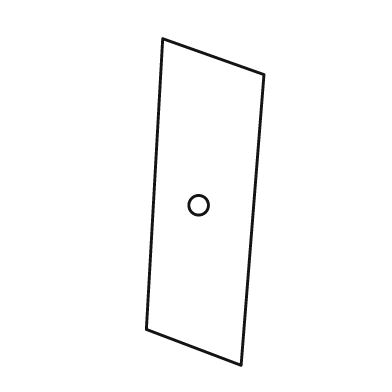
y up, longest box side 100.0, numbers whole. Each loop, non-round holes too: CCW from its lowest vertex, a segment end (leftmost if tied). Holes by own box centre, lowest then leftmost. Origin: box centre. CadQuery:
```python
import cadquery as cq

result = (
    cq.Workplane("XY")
    .moveTo(11.0, -50.0)
    .lineTo(18.0, 39.0)
    .lineTo(-13.0, 50.0)
    .lineTo(-18.0, -39.0)
    .close()
    .moveTo(-2.0, -1.0)
    .circle(3.0)
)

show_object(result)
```